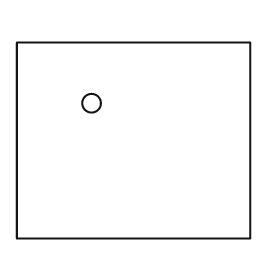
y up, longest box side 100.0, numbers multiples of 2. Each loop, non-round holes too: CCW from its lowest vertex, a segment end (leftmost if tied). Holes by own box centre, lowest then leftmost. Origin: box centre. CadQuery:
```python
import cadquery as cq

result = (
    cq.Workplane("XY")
    .moveTo(-50.0, -42.0)
    .lineTo(50.0, -42.0)
    .lineTo(50.0, 42.0)
    .lineTo(-50.0, 42.0)
    .close()
    .moveTo(-18.0, 16.0)
    .circle(4.0)
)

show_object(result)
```